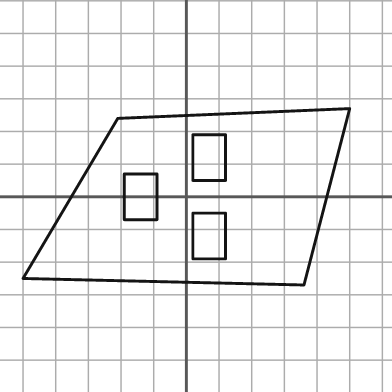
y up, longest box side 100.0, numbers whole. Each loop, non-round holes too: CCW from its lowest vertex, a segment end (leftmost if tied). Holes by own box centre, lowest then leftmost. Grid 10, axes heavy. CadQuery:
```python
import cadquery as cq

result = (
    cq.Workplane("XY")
    .moveTo(36.0, -27.0)
    .lineTo(50.0, 27.0)
    .lineTo(-21.0, 24.0)
    .lineTo(-50.0, -25.0)
    .close()
    .moveTo(2.0, -19.0)
    .lineTo(12.0, -19.0)
    .lineTo(12.0, -5.0)
    .lineTo(2.0, -5.0)
    .close()
    .moveTo(-19.0, -7.0)
    .lineTo(-9.0, -7.0)
    .lineTo(-9.0, 7.0)
    .lineTo(-19.0, 7.0)
    .close()
    .moveTo(2.0, 5.0)
    .lineTo(12.0, 5.0)
    .lineTo(12.0, 19.0)
    .lineTo(2.0, 19.0)
    .close()
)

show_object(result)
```